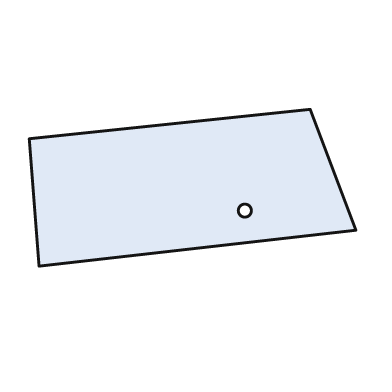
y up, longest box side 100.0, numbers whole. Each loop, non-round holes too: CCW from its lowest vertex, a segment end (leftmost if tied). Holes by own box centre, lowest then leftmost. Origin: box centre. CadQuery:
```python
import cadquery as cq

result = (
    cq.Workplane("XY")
    .moveTo(-47.0, -24.0)
    .lineTo(50.0, -13.0)
    .lineTo(36.0, 24.0)
    .lineTo(-50.0, 15.0)
    .close()
    .moveTo(16.0, -7.0)
    .circle(2.0)
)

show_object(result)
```